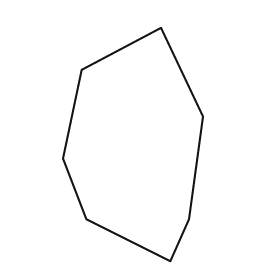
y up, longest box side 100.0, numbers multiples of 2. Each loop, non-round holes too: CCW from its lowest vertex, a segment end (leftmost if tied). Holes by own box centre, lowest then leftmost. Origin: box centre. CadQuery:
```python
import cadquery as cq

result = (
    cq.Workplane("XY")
    .moveTo(16.0, -50.0)
    .lineTo(24.0, -32.0)
    .lineTo(30.0, 12.0)
    .lineTo(12.0, 50.0)
    .lineTo(-22.0, 32.0)
    .lineTo(-30.0, -6.0)
    .lineTo(-20.0, -32.0)
    .close()
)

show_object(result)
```